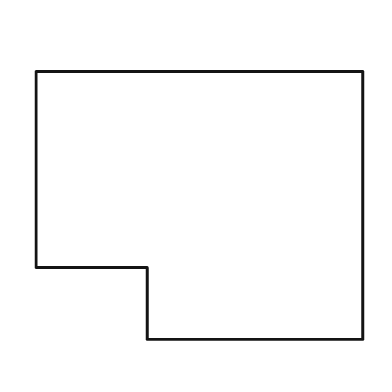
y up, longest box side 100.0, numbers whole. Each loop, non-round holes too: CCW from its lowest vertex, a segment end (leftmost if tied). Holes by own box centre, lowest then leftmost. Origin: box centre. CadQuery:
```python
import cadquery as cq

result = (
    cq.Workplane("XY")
    .moveTo(-16.0, -41.0)
    .lineTo(50.0, -41.0)
    .lineTo(50.0, 41.0)
    .lineTo(-50.0, 41.0)
    .lineTo(-50.0, -19.0)
    .lineTo(-16.0, -19.0)
    .close()
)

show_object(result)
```